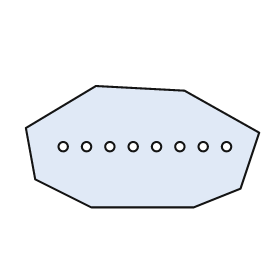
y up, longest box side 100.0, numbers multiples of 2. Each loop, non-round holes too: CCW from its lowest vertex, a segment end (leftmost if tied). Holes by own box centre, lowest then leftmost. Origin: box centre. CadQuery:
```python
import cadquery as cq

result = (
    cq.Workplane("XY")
    .moveTo(-22.0, -26.0)
    .lineTo(22.0, -26.0)
    .lineTo(42.0, -18.0)
    .lineTo(50.0, 6.0)
    .lineTo(18.0, 24.0)
    .lineTo(-20.0, 26.0)
    .lineTo(-50.0, 8.0)
    .lineTo(-46.0, -14.0)
    .close()
    .moveTo(-34.0, 0.0)
    .circle(2.0)
    .moveTo(-24.0, 0.0)
    .circle(2.0)
    .moveTo(-14.0, 0.0)
    .circle(2.0)
    .moveTo(-4.0, 0.0)
    .circle(2.0)
    .moveTo(6.0, 0.0)
    .circle(2.0)
    .moveTo(16.0, 0.0)
    .circle(2.0)
    .moveTo(26.0, 0.0)
    .circle(2.0)
    .moveTo(36.0, 0.0)
    .circle(2.0)
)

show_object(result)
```